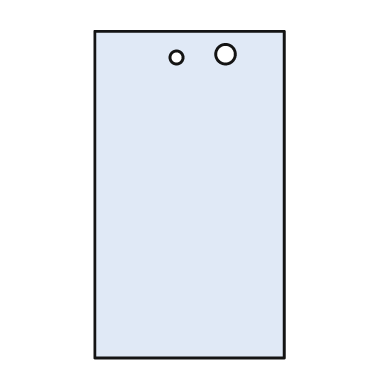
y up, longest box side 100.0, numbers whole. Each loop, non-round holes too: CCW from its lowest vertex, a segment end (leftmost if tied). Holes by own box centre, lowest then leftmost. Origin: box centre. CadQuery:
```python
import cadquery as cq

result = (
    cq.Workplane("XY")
    .moveTo(-29.0, -50.0)
    .lineTo(29.0, -50.0)
    .lineTo(29.0, 50.0)
    .lineTo(-29.0, 50.0)
    .close()
    .moveTo(-4.0, 42.0)
    .circle(2.0)
    .moveTo(11.0, 43.0)
    .circle(3.0)
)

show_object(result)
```